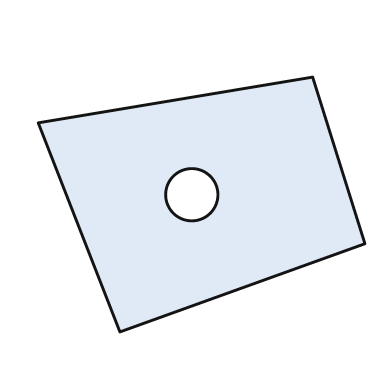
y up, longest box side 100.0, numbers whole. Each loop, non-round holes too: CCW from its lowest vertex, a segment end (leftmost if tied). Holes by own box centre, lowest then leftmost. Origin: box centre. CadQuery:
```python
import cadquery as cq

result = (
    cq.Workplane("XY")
    .moveTo(-25.0, -39.0)
    .lineTo(50.0, -12.0)
    .lineTo(34.0, 39.0)
    .lineTo(-50.0, 25.0)
    .close()
    .moveTo(-3.0, 3.0)
    .circle(8.0)
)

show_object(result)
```